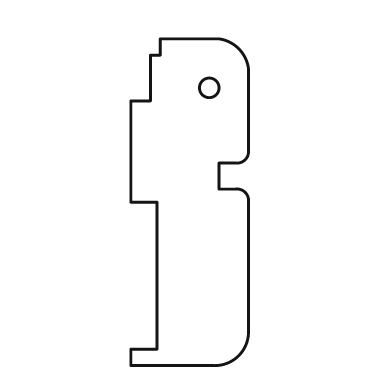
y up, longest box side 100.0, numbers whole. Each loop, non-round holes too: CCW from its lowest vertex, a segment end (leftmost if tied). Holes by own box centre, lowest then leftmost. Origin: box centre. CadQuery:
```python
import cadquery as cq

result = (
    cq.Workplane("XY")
    .moveTo(-18.0, -50.0)
    .lineTo(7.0, -50.0)
    .threePointArc((15.0, -47.0), (18.0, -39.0))
    .lineTo(18.0, 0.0)
    .threePointArc((17.0, 3.0), (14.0, 4.0))
    .lineTo(9.0, 4.0)
    .lineTo(9.0, 12.0)
    .lineTo(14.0, 12.0)
    .threePointArc((17.0, 13.0), (18.0, 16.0))
    .lineTo(18.0, 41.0)
    .threePointArc((15.0, 47.0), (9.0, 50.0))
    .lineTo(-9.0, 50.0)
    .lineTo(-9.0, 45.0)
    .lineTo(-12.0, 45.0)
    .lineTo(-12.0, 31.0)
    .lineTo(-18.0, 31.0)
    .lineTo(-18.0, 0.0)
    .lineTo(-10.0, 0.0)
    .lineTo(-10.0, -45.0)
    .lineTo(-18.0, -45.0)
    .close()
    .moveTo(6.0, 35.0)
    .circle(3.0)
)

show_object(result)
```